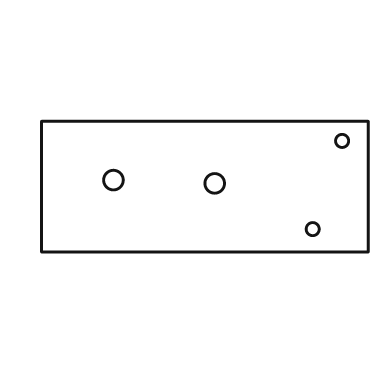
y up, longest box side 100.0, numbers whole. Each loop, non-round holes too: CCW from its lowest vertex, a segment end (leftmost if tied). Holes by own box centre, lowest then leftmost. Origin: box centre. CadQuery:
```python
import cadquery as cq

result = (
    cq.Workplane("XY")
    .moveTo(-50.0, -20.0)
    .lineTo(50.0, -20.0)
    .lineTo(50.0, 20.0)
    .lineTo(-50.0, 20.0)
    .close()
    .moveTo(33.0, -13.0)
    .circle(2.0)
    .moveTo(3.0, 1.0)
    .circle(3.0)
    .moveTo(-28.0, 2.0)
    .circle(3.0)
    .moveTo(42.0, 14.0)
    .circle(2.0)
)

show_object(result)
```